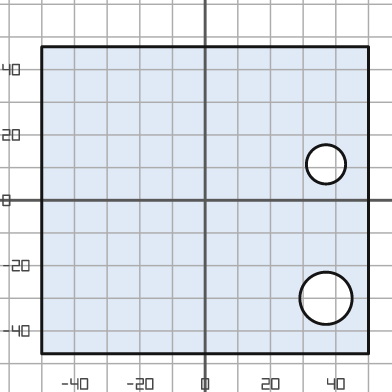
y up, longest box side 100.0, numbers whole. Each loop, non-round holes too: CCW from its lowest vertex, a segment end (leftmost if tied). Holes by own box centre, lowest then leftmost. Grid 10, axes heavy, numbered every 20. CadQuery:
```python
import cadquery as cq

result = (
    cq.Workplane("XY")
    .moveTo(-50.0, -47.0)
    .lineTo(50.0, -47.0)
    .lineTo(50.0, 47.0)
    .lineTo(-50.0, 47.0)
    .close()
    .moveTo(37.0, -30.0)
    .circle(8.0)
    .moveTo(37.0, 11.0)
    .circle(6.0)
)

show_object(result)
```